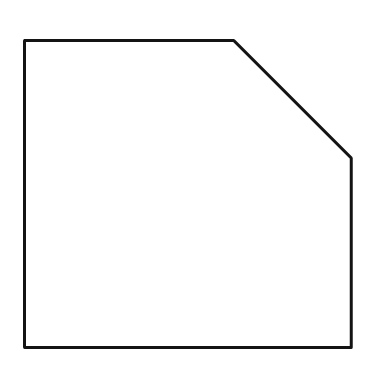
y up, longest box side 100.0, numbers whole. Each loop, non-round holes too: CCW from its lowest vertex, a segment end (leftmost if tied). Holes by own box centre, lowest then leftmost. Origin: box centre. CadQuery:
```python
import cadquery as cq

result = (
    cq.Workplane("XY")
    .moveTo(-50.0, -47.0)
    .lineTo(50.0, -47.0)
    .lineTo(50.0, 11.0)
    .lineTo(14.0, 47.0)
    .lineTo(-50.0, 47.0)
    .close()
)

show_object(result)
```